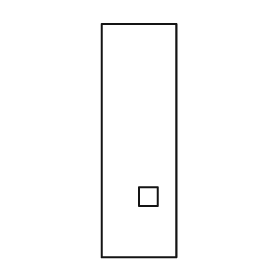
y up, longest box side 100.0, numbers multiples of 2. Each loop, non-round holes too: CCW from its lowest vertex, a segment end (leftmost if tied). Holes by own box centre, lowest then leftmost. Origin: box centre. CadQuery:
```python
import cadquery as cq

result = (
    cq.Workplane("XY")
    .moveTo(-16.0, -50.0)
    .lineTo(16.0, -50.0)
    .lineTo(16.0, 50.0)
    .lineTo(-16.0, 50.0)
    .close()
    .moveTo(0.0, -28.0)
    .lineTo(8.0, -28.0)
    .lineTo(8.0, -20.0)
    .lineTo(0.0, -20.0)
    .close()
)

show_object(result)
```